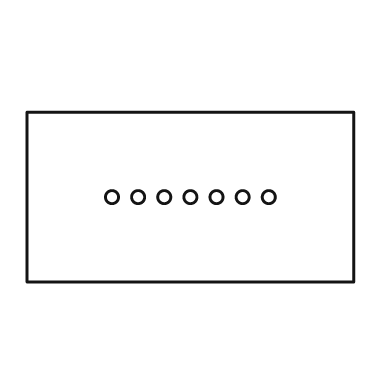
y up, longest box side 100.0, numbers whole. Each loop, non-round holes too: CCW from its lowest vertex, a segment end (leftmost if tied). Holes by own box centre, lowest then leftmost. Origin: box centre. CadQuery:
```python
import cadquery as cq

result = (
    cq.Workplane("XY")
    .moveTo(-50.0, -26.0)
    .lineTo(50.0, -26.0)
    .lineTo(50.0, 26.0)
    .lineTo(-50.0, 26.0)
    .close()
    .moveTo(-24.0, 0.0)
    .circle(2.0)
    .moveTo(-16.0, 0.0)
    .circle(2.0)
    .moveTo(-8.0, 0.0)
    .circle(2.0)
    .moveTo(0.0, 0.0)
    .circle(2.0)
    .moveTo(8.0, 0.0)
    .circle(2.0)
    .moveTo(16.0, 0.0)
    .circle(2.0)
    .moveTo(24.0, 0.0)
    .circle(2.0)
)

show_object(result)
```